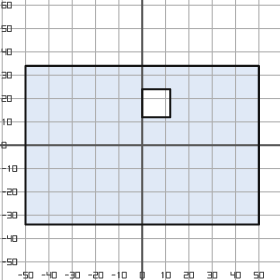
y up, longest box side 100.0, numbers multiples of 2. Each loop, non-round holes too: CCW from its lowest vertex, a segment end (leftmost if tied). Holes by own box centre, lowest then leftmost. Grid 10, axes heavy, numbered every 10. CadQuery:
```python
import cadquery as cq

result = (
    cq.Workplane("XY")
    .moveTo(-50.0, -34.0)
    .lineTo(50.0, -34.0)
    .lineTo(50.0, 34.0)
    .lineTo(-50.0, 34.0)
    .close()
    .moveTo(0.0, 12.0)
    .lineTo(12.0, 12.0)
    .lineTo(12.0, 24.0)
    .lineTo(0.0, 24.0)
    .close()
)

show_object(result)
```